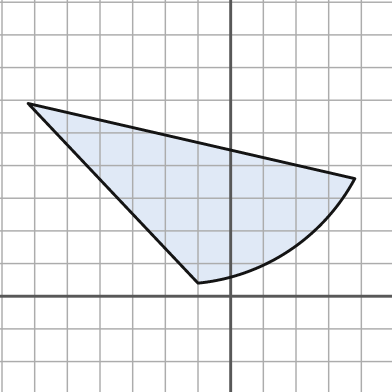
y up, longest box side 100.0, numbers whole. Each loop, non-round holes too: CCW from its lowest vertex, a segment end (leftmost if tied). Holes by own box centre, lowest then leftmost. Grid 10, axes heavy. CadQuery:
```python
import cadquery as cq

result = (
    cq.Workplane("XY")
    .moveTo(-10.0, 4.0)
    .threePointArc((18.0, 14.0), (38.0, 36.0))
    .lineTo(-62.0, 59.0)
    .close()
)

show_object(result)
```